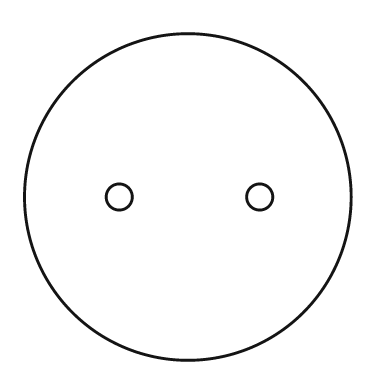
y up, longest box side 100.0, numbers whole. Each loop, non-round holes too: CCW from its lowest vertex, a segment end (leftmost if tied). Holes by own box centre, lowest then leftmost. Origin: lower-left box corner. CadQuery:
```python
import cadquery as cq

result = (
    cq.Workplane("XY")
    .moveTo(50.0, 50.0)
    .circle(50.0)
    .moveTo(29.0, 50.0)
    .circle(4.0)
    .moveTo(72.0, 50.0)
    .circle(4.0)
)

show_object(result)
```